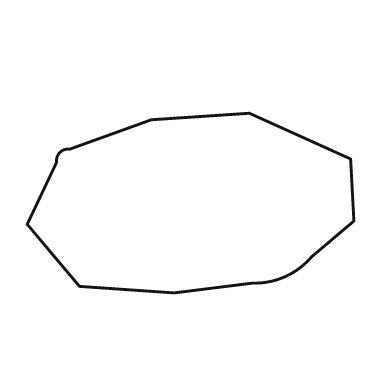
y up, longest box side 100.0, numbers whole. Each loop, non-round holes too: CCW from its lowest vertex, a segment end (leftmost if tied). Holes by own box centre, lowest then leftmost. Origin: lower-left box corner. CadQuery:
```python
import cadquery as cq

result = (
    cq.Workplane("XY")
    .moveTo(45.0, 0.0)
    .lineTo(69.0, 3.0)
    .threePointArc((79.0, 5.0), (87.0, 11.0))
    .lineTo(100.0, 22.0)
    .lineTo(99.0, 41.0)
    .lineTo(68.0, 55.0)
    .lineTo(38.0, 53.0)
    .lineTo(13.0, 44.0)
    .threePointArc((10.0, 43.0), (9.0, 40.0))
    .lineTo(0.0, 21.0)
    .lineTo(16.0, 2.0)
    .close()
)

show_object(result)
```